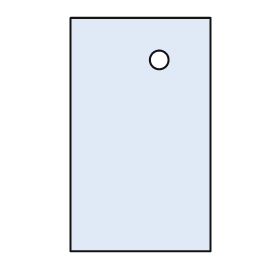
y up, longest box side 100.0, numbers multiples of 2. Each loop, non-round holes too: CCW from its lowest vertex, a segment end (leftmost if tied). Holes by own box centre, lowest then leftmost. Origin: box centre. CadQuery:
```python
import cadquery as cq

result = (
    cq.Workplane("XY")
    .moveTo(-30.0, -50.0)
    .lineTo(30.0, -50.0)
    .lineTo(30.0, 50.0)
    .lineTo(-30.0, 50.0)
    .close()
    .moveTo(8.0, 32.0)
    .circle(4.0)
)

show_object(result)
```